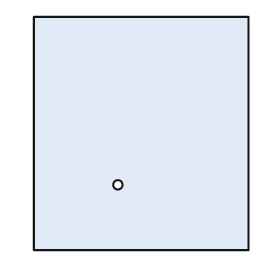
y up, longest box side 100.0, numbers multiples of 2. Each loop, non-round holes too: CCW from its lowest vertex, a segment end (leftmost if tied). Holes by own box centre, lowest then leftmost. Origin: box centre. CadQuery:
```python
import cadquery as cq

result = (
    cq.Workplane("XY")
    .moveTo(-46.0, -50.0)
    .lineTo(46.0, -50.0)
    .lineTo(46.0, 50.0)
    .lineTo(-46.0, 50.0)
    .close()
    .moveTo(-10.0, -22.0)
    .circle(2.0)
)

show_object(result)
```